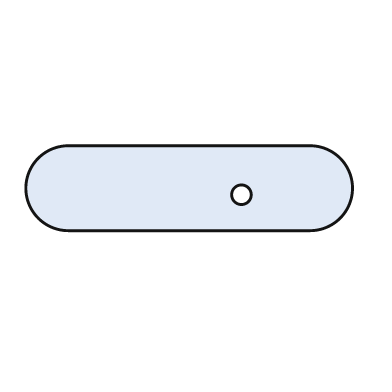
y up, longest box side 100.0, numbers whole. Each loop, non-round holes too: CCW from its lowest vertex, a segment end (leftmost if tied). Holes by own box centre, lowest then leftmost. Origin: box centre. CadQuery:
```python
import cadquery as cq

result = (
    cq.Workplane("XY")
    .moveTo(-37.0, -13.0)
    .lineTo(37.0, -13.0)
    .threePointArc((50.0, 0.0), (37.0, 13.0))
    .lineTo(-37.0, 13.0)
    .threePointArc((-50.0, 0.0), (-37.0, -13.0))
    .close()
    .moveTo(16.0, -2.0)
    .circle(3.0)
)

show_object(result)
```